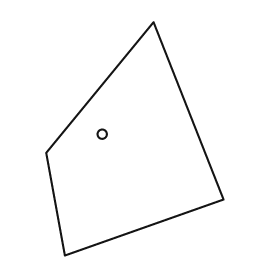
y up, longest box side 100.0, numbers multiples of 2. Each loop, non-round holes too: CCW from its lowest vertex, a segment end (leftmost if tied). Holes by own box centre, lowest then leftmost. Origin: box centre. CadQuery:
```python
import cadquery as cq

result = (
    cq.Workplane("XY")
    .moveTo(-30.0, -50.0)
    .lineTo(38.0, -26.0)
    .lineTo(8.0, 50.0)
    .lineTo(-38.0, -6.0)
    .close()
    .moveTo(-14.0, 2.0)
    .circle(2.0)
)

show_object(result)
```